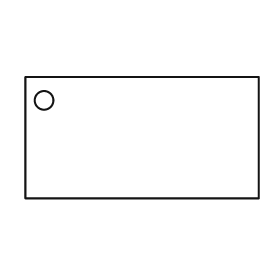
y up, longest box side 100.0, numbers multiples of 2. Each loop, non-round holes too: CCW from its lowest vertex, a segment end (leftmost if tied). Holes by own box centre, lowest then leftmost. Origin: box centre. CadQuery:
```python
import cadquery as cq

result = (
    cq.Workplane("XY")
    .moveTo(-50.0, -26.0)
    .lineTo(50.0, -26.0)
    .lineTo(50.0, 26.0)
    .lineTo(-50.0, 26.0)
    .close()
    .moveTo(-42.0, 16.0)
    .circle(4.0)
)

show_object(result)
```